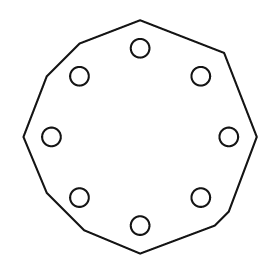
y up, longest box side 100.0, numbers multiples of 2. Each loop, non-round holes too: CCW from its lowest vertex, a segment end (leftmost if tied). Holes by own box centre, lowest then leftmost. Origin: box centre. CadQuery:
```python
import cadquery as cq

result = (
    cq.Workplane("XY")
    .moveTo(0.0, -50.0)
    .lineTo(32.0, -38.0)
    .lineTo(38.0, -32.0)
    .lineTo(50.0, 0.0)
    .lineTo(36.0, 36.0)
    .lineTo(0.0, 50.0)
    .lineTo(-26.0, 40.0)
    .lineTo(-40.0, 26.0)
    .lineTo(-50.0, 0.0)
    .lineTo(-40.0, -24.0)
    .lineTo(-24.0, -40.0)
    .close()
    .moveTo(0.0, -38.0)
    .circle(4.0)
    .moveTo(-26.0, -26.0)
    .circle(4.0)
    .moveTo(26.0, -26.0)
    .circle(4.0)
    .moveTo(-38.0, 0.0)
    .circle(4.0)
    .moveTo(38.0, 0.0)
    .circle(4.0)
    .moveTo(-26.0, 26.0)
    .circle(4.0)
    .moveTo(26.0, 26.0)
    .circle(4.0)
    .moveTo(0.0, 38.0)
    .circle(4.0)
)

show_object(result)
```